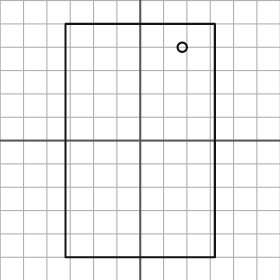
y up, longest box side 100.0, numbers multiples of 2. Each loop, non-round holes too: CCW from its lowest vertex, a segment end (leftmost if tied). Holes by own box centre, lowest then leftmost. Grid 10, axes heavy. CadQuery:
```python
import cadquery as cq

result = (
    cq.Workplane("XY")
    .moveTo(-32.0, -50.0)
    .lineTo(32.0, -50.0)
    .lineTo(32.0, 50.0)
    .lineTo(-32.0, 50.0)
    .close()
    .moveTo(18.0, 40.0)
    .circle(2.0)
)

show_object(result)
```